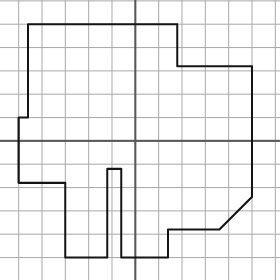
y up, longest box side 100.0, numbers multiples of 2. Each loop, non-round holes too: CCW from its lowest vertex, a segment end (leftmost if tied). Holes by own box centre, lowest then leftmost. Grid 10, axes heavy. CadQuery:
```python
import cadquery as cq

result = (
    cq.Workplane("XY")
    .moveTo(-30.0, -50.0)
    .lineTo(-12.0, -50.0)
    .lineTo(-12.0, -12.0)
    .lineTo(-6.0, -12.0)
    .lineTo(-6.0, -50.0)
    .lineTo(14.0, -50.0)
    .lineTo(14.0, -38.0)
    .lineTo(36.0, -38.0)
    .lineTo(50.0, -24.0)
    .lineTo(50.0, 32.0)
    .lineTo(18.0, 32.0)
    .lineTo(18.0, 50.0)
    .lineTo(-46.0, 50.0)
    .lineTo(-46.0, 10.0)
    .lineTo(-50.0, 10.0)
    .lineTo(-50.0, -18.0)
    .lineTo(-30.0, -18.0)
    .close()
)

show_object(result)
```